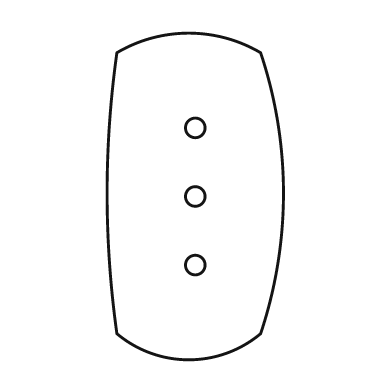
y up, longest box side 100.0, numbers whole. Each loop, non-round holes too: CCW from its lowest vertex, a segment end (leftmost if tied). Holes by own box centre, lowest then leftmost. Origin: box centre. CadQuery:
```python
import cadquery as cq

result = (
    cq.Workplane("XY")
    .moveTo(-24.0, -42.0)
    .threePointArc((-2.0, -50.0), (20.0, -42.0))
    .threePointArc((27.0, 1.0), (20.0, 44.0))
    .threePointArc((-2.0, 50.0), (-24.0, 44.0))
    .threePointArc((-27.0, 1.0), (-24.0, -42.0))
    .close()
    .moveTo(0.0, -21.0)
    .circle(3.0)
    .moveTo(0.0, 0.0)
    .circle(3.0)
    .moveTo(0.0, 21.0)
    .circle(3.0)
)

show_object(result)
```